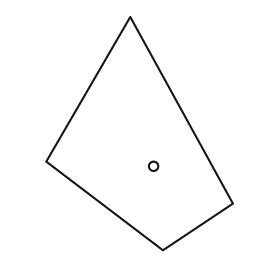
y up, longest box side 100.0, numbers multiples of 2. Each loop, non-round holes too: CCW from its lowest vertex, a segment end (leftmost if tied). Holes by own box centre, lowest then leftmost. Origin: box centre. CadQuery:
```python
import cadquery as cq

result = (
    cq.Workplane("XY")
    .moveTo(10.0, -50.0)
    .lineTo(40.0, -30.0)
    .lineTo(-4.0, 50.0)
    .lineTo(-40.0, -12.0)
    .close()
    .moveTo(6.0, -14.0)
    .circle(2.0)
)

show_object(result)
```